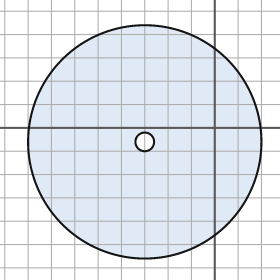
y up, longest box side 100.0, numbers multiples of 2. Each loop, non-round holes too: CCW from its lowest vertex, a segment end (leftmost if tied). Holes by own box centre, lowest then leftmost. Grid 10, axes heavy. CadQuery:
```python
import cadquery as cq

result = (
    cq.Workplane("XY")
    .moveTo(-30.0, -6.0)
    .circle(50.0)
    .moveTo(-30.0, -6.0)
    .circle(4.0)
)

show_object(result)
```